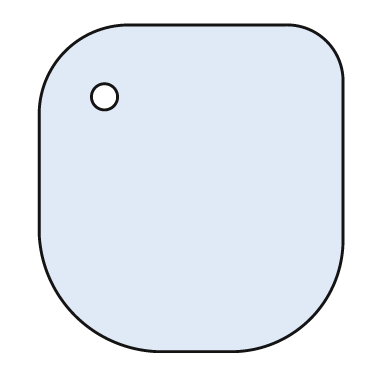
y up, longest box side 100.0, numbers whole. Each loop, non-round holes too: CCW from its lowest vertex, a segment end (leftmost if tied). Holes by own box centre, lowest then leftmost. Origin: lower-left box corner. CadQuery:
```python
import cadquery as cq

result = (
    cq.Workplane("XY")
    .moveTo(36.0, 0.0)
    .lineTo(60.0, 0.0)
    .threePointArc((83.0, 10.0), (93.0, 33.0))
    .lineTo(93.0, 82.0)
    .threePointArc((88.0, 95.0), (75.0, 100.0))
    .lineTo(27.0, 100.0)
    .threePointArc((8.0, 92.0), (0.0, 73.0))
    .lineTo(0.0, 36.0)
    .threePointArc((11.0, 11.0), (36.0, 0.0))
    .close()
    .moveTo(20.0, 78.0)
    .circle(4.0)
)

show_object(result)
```